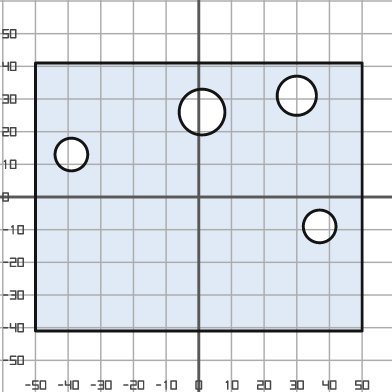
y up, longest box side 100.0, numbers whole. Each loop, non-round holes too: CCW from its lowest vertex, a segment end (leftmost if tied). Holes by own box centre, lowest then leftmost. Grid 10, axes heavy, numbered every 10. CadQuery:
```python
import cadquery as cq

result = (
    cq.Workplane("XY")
    .moveTo(-50.0, -41.0)
    .lineTo(50.0, -41.0)
    .lineTo(50.0, 41.0)
    .lineTo(-50.0, 41.0)
    .close()
    .moveTo(37.0, -9.0)
    .circle(5.0)
    .moveTo(-39.0, 13.0)
    .circle(5.0)
    .moveTo(1.0, 26.0)
    .circle(7.0)
    .moveTo(30.0, 31.0)
    .circle(6.0)
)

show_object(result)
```